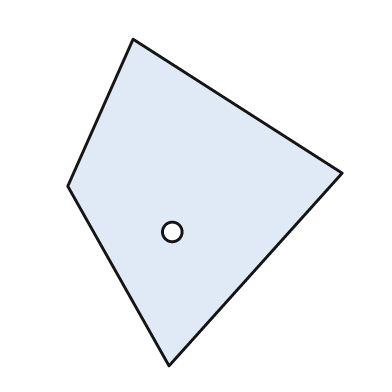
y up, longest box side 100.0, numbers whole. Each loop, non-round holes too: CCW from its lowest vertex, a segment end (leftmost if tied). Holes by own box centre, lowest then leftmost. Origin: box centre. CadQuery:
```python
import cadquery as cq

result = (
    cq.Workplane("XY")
    .moveTo(-11.0, -50.0)
    .lineTo(42.0, 9.0)
    .lineTo(-22.0, 50.0)
    .lineTo(-42.0, 5.0)
    .close()
    .moveTo(-10.0, -9.0)
    .circle(3.0)
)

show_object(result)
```